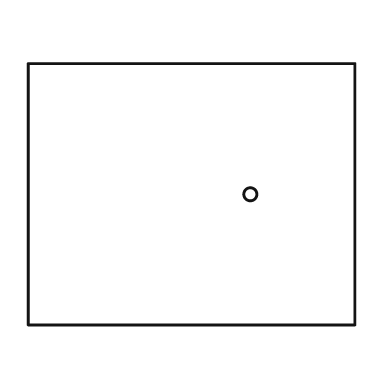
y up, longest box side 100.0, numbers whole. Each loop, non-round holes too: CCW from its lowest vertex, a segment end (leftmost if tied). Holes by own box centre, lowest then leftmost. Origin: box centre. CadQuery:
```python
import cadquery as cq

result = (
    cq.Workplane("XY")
    .moveTo(-50.0, -40.0)
    .lineTo(50.0, -40.0)
    .lineTo(50.0, 40.0)
    .lineTo(-50.0, 40.0)
    .close()
    .moveTo(18.0, 0.0)
    .circle(2.0)
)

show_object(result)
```